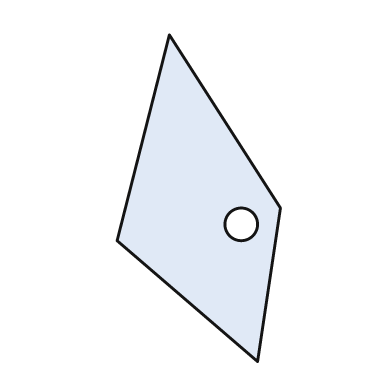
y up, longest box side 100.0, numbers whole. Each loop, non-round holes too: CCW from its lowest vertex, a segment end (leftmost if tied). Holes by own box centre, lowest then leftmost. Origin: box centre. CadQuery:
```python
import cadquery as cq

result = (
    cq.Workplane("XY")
    .moveTo(18.0, -50.0)
    .lineTo(25.0, -3.0)
    .lineTo(-9.0, 50.0)
    .lineTo(-25.0, -13.0)
    .close()
    .moveTo(13.0, -8.0)
    .circle(5.0)
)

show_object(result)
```